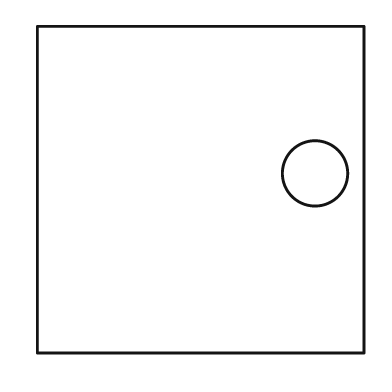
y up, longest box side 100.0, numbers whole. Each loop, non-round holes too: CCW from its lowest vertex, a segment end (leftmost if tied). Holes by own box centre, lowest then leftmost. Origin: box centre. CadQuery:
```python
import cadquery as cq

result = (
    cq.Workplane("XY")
    .moveTo(-50.0, -50.0)
    .lineTo(50.0, -50.0)
    .lineTo(50.0, 50.0)
    .lineTo(-50.0, 50.0)
    .close()
    .moveTo(35.0, 5.0)
    .circle(10.0)
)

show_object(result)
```